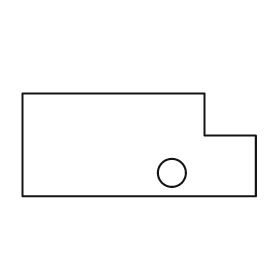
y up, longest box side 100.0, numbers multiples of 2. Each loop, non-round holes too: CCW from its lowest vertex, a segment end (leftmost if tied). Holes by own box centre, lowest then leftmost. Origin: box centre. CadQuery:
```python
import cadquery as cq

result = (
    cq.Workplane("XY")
    .moveTo(-50.0, -22.0)
    .lineTo(50.0, -22.0)
    .lineTo(50.0, 4.0)
    .lineTo(28.0, 4.0)
    .lineTo(28.0, 22.0)
    .lineTo(-50.0, 22.0)
    .close()
    .moveTo(14.0, -12.0)
    .circle(6.0)
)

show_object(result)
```